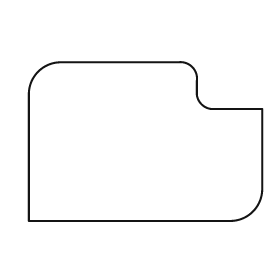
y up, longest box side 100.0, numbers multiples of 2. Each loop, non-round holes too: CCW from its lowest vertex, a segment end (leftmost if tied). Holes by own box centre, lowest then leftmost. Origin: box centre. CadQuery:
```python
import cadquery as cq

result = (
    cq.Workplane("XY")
    .moveTo(-50.0, -34.0)
    .lineTo(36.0, -34.0)
    .threePointArc((46.0, -30.0), (50.0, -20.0))
    .lineTo(50.0, 14.0)
    .lineTo(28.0, 14.0)
    .threePointArc((24.0, 16.0), (22.0, 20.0))
    .lineTo(22.0, 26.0)
    .threePointArc((20.0, 32.0), (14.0, 34.0))
    .lineTo(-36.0, 34.0)
    .threePointArc((-46.0, 30.0), (-50.0, 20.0))
    .close()
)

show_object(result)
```